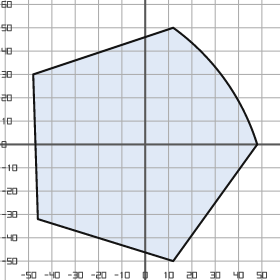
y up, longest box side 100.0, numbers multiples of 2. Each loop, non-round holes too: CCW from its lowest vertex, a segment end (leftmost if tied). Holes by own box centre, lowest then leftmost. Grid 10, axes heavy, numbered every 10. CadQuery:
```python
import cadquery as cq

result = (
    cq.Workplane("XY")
    .moveTo(12.0, -50.0)
    .lineTo(48.0, 0.0)
    .threePointArc((34.0, 28.0), (12.0, 50.0))
    .lineTo(-48.0, 30.0)
    .lineTo(-46.0, -32.0)
    .close()
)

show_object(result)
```